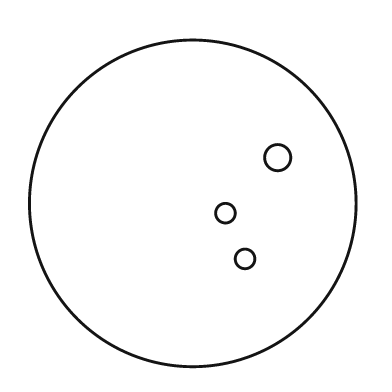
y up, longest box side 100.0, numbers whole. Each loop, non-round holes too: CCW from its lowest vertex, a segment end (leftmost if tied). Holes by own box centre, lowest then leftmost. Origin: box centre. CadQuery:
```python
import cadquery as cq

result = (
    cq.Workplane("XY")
    .moveTo(0.0, 0.0)
    .circle(50.0)
    .moveTo(16.0, -17.0)
    .circle(3.0)
    .moveTo(10.0, -3.0)
    .circle(3.0)
    .moveTo(26.0, 14.0)
    .circle(4.0)
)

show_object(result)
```